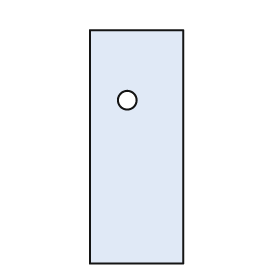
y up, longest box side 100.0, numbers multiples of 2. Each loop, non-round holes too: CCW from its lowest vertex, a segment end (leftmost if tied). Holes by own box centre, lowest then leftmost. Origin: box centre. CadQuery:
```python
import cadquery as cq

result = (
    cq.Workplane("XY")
    .moveTo(-20.0, -50.0)
    .lineTo(20.0, -50.0)
    .lineTo(20.0, 50.0)
    .lineTo(-20.0, 50.0)
    .close()
    .moveTo(-4.0, 20.0)
    .circle(4.0)
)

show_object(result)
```